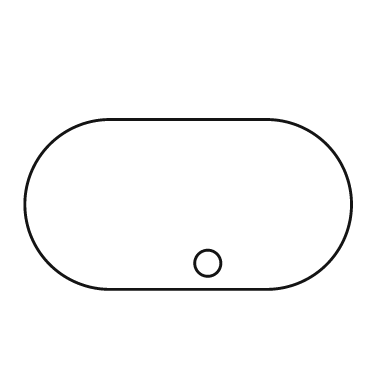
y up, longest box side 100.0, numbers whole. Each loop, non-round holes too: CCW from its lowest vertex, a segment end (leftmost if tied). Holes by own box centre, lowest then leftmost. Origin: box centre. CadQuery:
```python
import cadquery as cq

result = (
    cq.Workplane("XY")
    .moveTo(-24.0, -26.0)
    .lineTo(24.0, -26.0)
    .threePointArc((50.0, 0.0), (24.0, 26.0))
    .lineTo(-24.0, 26.0)
    .threePointArc((-50.0, 0.0), (-24.0, -26.0))
    .close()
    .moveTo(6.0, -18.0)
    .circle(4.0)
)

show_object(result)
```